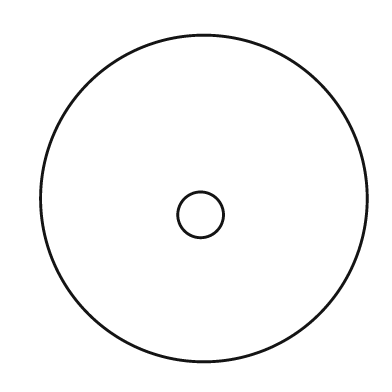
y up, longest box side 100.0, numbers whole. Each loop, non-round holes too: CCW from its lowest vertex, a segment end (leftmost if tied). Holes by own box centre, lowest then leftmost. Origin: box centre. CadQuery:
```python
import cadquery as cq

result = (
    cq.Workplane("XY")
    .moveTo(0.0, 0.0)
    .circle(50.0)
    .moveTo(-1.0, -5.0)
    .circle(7.0)
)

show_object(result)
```